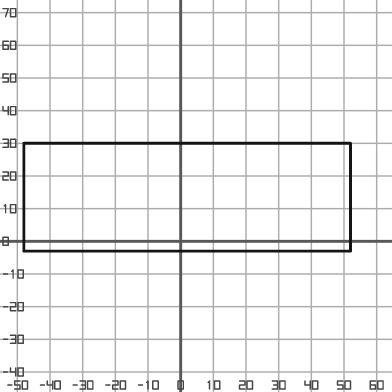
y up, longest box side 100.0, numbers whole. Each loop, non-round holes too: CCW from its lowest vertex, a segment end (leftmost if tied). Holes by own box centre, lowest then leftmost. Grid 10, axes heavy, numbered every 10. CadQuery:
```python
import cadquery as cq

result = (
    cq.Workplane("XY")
    .moveTo(-48.0, -3.0)
    .lineTo(52.0, -3.0)
    .lineTo(52.0, 30.0)
    .lineTo(-48.0, 30.0)
    .close()
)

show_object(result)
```